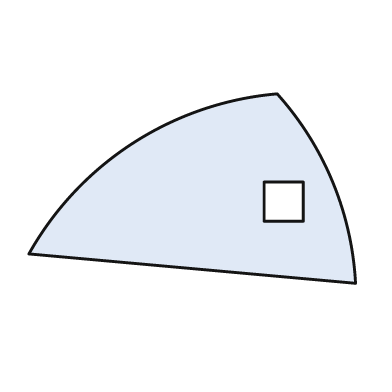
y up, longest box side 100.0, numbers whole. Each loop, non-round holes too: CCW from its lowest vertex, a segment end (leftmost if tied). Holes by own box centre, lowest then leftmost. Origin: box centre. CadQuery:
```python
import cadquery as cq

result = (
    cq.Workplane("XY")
    .moveTo(50.0, -29.0)
    .threePointArc((43.0, 2.0), (26.0, 29.0))
    .threePointArc((-18.0, 14.0), (-50.0, -20.0))
    .close()
    .moveTo(22.0, -10.0)
    .lineTo(34.0, -10.0)
    .lineTo(34.0, 2.0)
    .lineTo(22.0, 2.0)
    .close()
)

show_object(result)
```